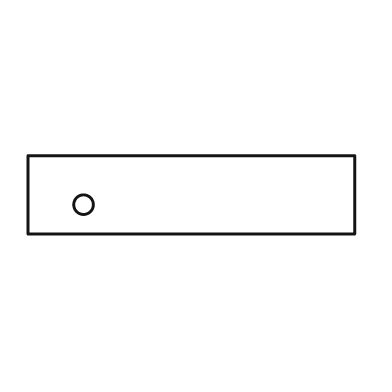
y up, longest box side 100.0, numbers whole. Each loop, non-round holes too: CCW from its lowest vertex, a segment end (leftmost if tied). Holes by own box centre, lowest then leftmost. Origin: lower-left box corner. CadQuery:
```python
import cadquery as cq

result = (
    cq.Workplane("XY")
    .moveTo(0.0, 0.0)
    .lineTo(100.0, 0.0)
    .lineTo(100.0, 24.0)
    .lineTo(0.0, 24.0)
    .close()
    .moveTo(17.0, 9.0)
    .circle(3.0)
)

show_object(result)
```